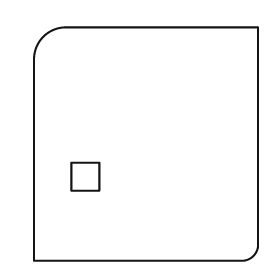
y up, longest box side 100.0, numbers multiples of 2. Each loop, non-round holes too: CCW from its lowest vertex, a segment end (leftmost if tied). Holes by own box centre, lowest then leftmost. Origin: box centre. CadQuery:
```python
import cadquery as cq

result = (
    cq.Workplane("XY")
    .moveTo(-48.0, -50.0)
    .lineTo(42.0, -50.0)
    .threePointArc((46.0, -48.0), (48.0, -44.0))
    .lineTo(48.0, 50.0)
    .lineTo(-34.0, 50.0)
    .threePointArc((-44.0, 46.0), (-48.0, 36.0))
    .close()
    .moveTo(-32.0, -20.0)
    .lineTo(-20.0, -20.0)
    .lineTo(-20.0, -8.0)
    .lineTo(-32.0, -8.0)
    .close()
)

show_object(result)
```